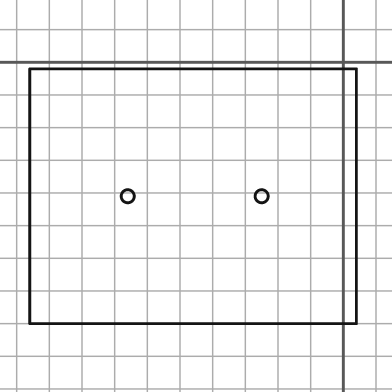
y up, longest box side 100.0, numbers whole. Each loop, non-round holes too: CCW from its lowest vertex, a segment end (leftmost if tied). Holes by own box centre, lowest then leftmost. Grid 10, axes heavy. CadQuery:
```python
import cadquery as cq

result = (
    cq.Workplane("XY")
    .moveTo(-96.0, -80.0)
    .lineTo(4.0, -80.0)
    .lineTo(4.0, -2.0)
    .lineTo(-96.0, -2.0)
    .close()
    .moveTo(-66.0, -41.0)
    .circle(2.0)
    .moveTo(-25.0, -41.0)
    .circle(2.0)
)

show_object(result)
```